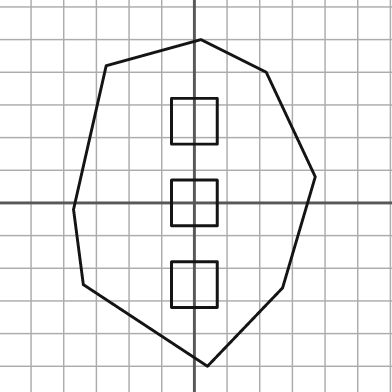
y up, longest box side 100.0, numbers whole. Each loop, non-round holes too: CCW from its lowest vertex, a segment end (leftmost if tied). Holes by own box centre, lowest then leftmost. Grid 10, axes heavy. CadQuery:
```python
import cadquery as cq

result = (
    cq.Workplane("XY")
    .moveTo(4.0, -50.0)
    .lineTo(27.0, -26.0)
    .lineTo(37.0, 8.0)
    .lineTo(22.0, 40.0)
    .lineTo(2.0, 50.0)
    .lineTo(-27.0, 42.0)
    .lineTo(-37.0, -2.0)
    .lineTo(-34.0, -25.0)
    .close()
    .moveTo(-7.0, -32.0)
    .lineTo(7.0, -32.0)
    .lineTo(7.0, -18.0)
    .lineTo(-7.0, -18.0)
    .close()
    .moveTo(-7.0, -7.0)
    .lineTo(7.0, -7.0)
    .lineTo(7.0, 7.0)
    .lineTo(-7.0, 7.0)
    .close()
    .moveTo(-7.0, 18.0)
    .lineTo(7.0, 18.0)
    .lineTo(7.0, 32.0)
    .lineTo(-7.0, 32.0)
    .close()
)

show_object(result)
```